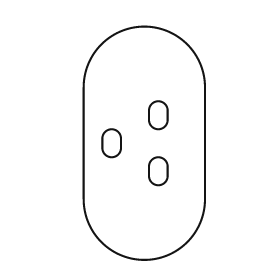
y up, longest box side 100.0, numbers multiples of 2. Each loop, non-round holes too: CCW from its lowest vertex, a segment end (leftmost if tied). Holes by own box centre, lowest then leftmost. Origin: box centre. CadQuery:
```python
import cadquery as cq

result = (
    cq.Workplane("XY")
    .moveTo(-26.0, -24.0)
    .threePointArc((0.0, -50.0), (26.0, -24.0))
    .lineTo(26.0, 24.0)
    .threePointArc((0.0, 50.0), (-26.0, 24.0))
    .close()
    .moveTo(2.0, -14.0)
    .threePointArc((6.0, -18.0), (10.0, -14.0))
    .lineTo(10.0, -10.0)
    .threePointArc((6.0, -6.0), (2.0, -10.0))
    .close()
    .moveTo(-18.0, -2.0)
    .threePointArc((-14.0, -6.0), (-10.0, -2.0))
    .lineTo(-10.0, 2.0)
    .threePointArc((-14.0, 6.0), (-18.0, 2.0))
    .close()
    .moveTo(2.0, 10.0)
    .threePointArc((6.0, 6.0), (10.0, 10.0))
    .lineTo(10.0, 14.0)
    .threePointArc((6.0, 18.0), (2.0, 14.0))
    .close()
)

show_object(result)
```